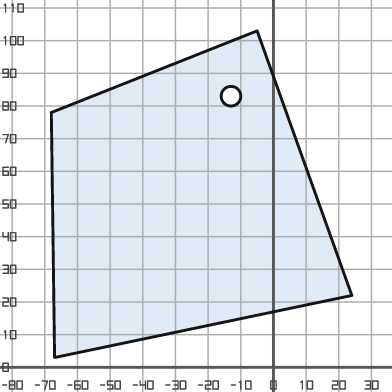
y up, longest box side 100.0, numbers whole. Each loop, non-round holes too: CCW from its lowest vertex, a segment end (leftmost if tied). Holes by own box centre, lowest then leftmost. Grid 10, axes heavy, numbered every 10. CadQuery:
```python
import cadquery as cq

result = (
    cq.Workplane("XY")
    .moveTo(-67.0, 3.0)
    .lineTo(24.0, 22.0)
    .lineTo(-5.0, 103.0)
    .lineTo(-68.0, 78.0)
    .close()
    .moveTo(-13.0, 83.0)
    .circle(3.0)
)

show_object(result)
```